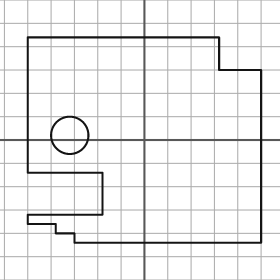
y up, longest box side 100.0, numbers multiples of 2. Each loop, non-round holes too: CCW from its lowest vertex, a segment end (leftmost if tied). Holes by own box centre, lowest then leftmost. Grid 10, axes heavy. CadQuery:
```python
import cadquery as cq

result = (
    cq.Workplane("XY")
    .moveTo(-30.0, -44.0)
    .lineTo(50.0, -44.0)
    .lineTo(50.0, 30.0)
    .lineTo(32.0, 30.0)
    .lineTo(32.0, 44.0)
    .lineTo(-50.0, 44.0)
    .lineTo(-50.0, -14.0)
    .lineTo(-18.0, -14.0)
    .lineTo(-18.0, -32.0)
    .lineTo(-50.0, -32.0)
    .lineTo(-50.0, -36.0)
    .lineTo(-38.0, -36.0)
    .lineTo(-38.0, -40.0)
    .lineTo(-30.0, -40.0)
    .close()
    .moveTo(-32.0, 2.0)
    .circle(8.0)
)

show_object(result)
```